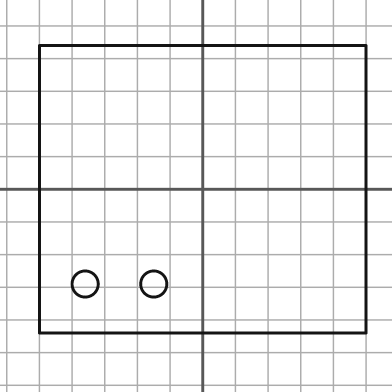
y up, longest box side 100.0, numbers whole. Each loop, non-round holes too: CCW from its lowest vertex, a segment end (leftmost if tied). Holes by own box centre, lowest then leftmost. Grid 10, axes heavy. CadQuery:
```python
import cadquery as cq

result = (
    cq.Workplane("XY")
    .moveTo(-50.0, -44.0)
    .lineTo(50.0, -44.0)
    .lineTo(50.0, 44.0)
    .lineTo(-50.0, 44.0)
    .close()
    .moveTo(-36.0, -29.0)
    .circle(4.0)
    .moveTo(-15.0, -29.0)
    .circle(4.0)
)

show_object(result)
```